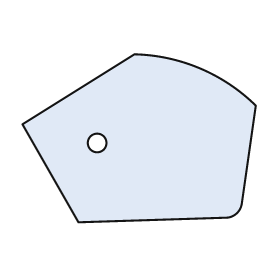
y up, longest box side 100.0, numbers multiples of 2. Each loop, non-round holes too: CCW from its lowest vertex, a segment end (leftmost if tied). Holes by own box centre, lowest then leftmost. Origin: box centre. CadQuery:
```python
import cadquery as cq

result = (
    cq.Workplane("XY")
    .moveTo(-26.0, -36.0)
    .lineTo(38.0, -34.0)
    .threePointArc((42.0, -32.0), (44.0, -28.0))
    .lineTo(50.0, 14.0)
    .threePointArc((26.0, 30.0), (-2.0, 36.0))
    .lineTo(-50.0, 6.0)
    .close()
    .moveTo(-18.0, -2.0)
    .circle(4.0)
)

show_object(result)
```